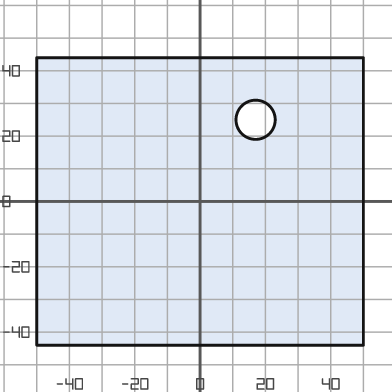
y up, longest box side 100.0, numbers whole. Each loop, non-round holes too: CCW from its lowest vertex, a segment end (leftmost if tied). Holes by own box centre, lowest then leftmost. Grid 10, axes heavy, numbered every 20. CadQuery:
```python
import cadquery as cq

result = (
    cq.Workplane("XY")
    .moveTo(-50.0, -44.0)
    .lineTo(50.0, -44.0)
    .lineTo(50.0, 44.0)
    .lineTo(-50.0, 44.0)
    .close()
    .moveTo(17.0, 25.0)
    .circle(6.0)
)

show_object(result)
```